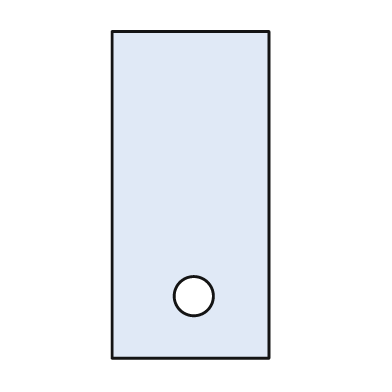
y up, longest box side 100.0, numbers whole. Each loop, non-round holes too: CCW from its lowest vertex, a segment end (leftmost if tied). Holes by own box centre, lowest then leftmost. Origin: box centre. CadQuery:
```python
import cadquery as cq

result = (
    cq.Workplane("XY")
    .moveTo(-24.0, -50.0)
    .lineTo(24.0, -50.0)
    .lineTo(24.0, 50.0)
    .lineTo(-24.0, 50.0)
    .close()
    .moveTo(1.0, -31.0)
    .circle(6.0)
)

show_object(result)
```